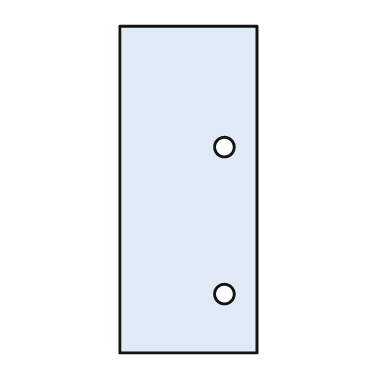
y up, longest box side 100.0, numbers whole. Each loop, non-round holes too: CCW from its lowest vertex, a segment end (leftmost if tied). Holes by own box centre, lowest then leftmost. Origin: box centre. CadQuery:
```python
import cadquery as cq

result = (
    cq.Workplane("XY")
    .moveTo(-21.0, -50.0)
    .lineTo(21.0, -50.0)
    .lineTo(21.0, 50.0)
    .lineTo(-21.0, 50.0)
    .close()
    .moveTo(11.0, -32.0)
    .circle(3.0)
    .moveTo(11.0, 13.0)
    .circle(3.0)
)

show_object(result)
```